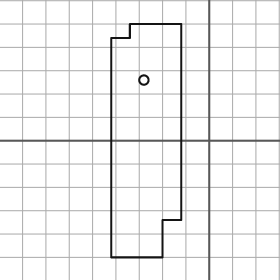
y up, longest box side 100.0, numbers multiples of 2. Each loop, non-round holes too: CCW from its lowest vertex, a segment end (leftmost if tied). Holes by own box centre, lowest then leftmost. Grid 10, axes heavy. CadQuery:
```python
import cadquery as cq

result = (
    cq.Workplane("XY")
    .moveTo(-42.0, -50.0)
    .lineTo(-20.0, -50.0)
    .lineTo(-20.0, -34.0)
    .lineTo(-12.0, -34.0)
    .lineTo(-12.0, 50.0)
    .lineTo(-34.0, 50.0)
    .lineTo(-34.0, 44.0)
    .lineTo(-42.0, 44.0)
    .close()
    .moveTo(-28.0, 26.0)
    .circle(2.0)
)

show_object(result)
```